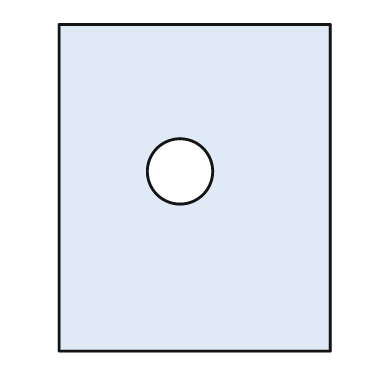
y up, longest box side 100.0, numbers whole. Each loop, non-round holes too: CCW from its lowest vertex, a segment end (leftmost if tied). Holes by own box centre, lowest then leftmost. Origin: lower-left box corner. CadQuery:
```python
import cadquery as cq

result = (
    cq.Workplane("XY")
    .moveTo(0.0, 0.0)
    .lineTo(83.0, 0.0)
    .lineTo(83.0, 100.0)
    .lineTo(0.0, 100.0)
    .close()
    .moveTo(37.0, 55.0)
    .circle(10.0)
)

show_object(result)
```